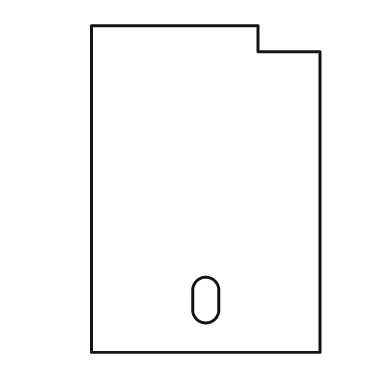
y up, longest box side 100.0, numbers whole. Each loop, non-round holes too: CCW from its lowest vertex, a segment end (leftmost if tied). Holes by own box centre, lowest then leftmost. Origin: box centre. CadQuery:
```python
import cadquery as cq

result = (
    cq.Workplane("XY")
    .moveTo(-35.0, -50.0)
    .lineTo(35.0, -50.0)
    .lineTo(35.0, 42.0)
    .lineTo(16.0, 42.0)
    .lineTo(16.0, 50.0)
    .lineTo(-35.0, 50.0)
    .close()
    .moveTo(-4.0, -37.0)
    .threePointArc((0.0, -41.0), (4.0, -37.0))
    .lineTo(4.0, -31.0)
    .threePointArc((0.0, -27.0), (-4.0, -31.0))
    .close()
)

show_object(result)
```